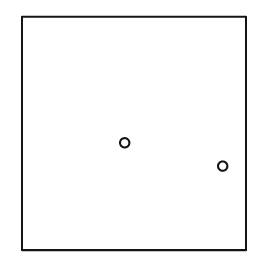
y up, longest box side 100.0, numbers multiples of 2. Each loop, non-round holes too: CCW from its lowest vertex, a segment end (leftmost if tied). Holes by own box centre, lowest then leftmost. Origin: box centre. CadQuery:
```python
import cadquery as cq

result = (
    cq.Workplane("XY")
    .moveTo(-48.0, -50.0)
    .lineTo(48.0, -50.0)
    .lineTo(48.0, 50.0)
    .lineTo(-48.0, 50.0)
    .close()
    .moveTo(38.0, -14.0)
    .circle(2.0)
    .moveTo(-4.0, -4.0)
    .circle(2.0)
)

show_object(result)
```